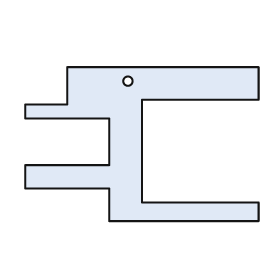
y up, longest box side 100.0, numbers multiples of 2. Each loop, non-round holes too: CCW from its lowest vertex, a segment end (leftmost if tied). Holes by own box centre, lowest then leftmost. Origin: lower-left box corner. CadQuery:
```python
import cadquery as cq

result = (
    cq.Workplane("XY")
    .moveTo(36.0, 0.0)
    .lineTo(100.0, 0.0)
    .lineTo(100.0, 8.0)
    .lineTo(50.0, 8.0)
    .lineTo(50.0, 52.0)
    .lineTo(100.0, 52.0)
    .lineTo(100.0, 66.0)
    .lineTo(18.0, 66.0)
    .lineTo(18.0, 50.0)
    .lineTo(0.0, 50.0)
    .lineTo(0.0, 44.0)
    .lineTo(36.0, 44.0)
    .lineTo(36.0, 24.0)
    .lineTo(0.0, 24.0)
    .lineTo(0.0, 14.0)
    .lineTo(36.0, 14.0)
    .close()
    .moveTo(44.0, 60.0)
    .circle(2.0)
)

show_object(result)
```